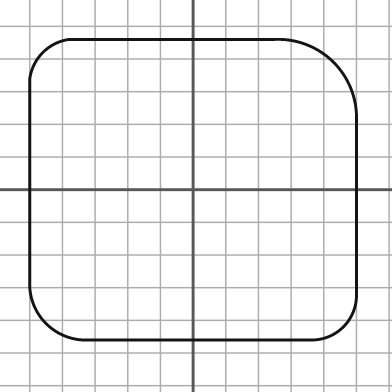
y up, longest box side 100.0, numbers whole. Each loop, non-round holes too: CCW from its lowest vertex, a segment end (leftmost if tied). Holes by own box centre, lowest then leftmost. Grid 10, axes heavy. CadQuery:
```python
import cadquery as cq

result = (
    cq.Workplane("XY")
    .moveTo(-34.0, -46.0)
    .lineTo(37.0, -46.0)
    .threePointArc((46.0, -42.0), (50.0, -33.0))
    .lineTo(50.0, 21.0)
    .threePointArc((43.0, 39.0), (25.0, 46.0))
    .lineTo(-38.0, 46.0)
    .threePointArc((-46.0, 42.0), (-50.0, 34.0))
    .lineTo(-50.0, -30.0)
    .threePointArc((-45.0, -41.0), (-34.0, -46.0))
    .close()
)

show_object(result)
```